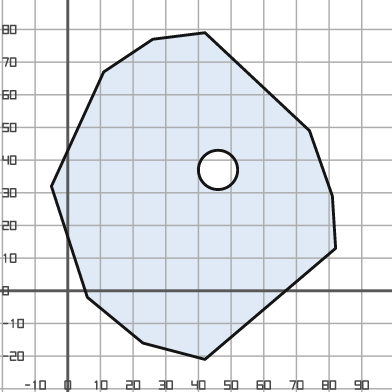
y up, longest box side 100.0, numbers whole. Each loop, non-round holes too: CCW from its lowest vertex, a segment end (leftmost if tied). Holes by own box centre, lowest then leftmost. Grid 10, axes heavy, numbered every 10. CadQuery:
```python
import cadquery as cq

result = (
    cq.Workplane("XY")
    .moveTo(42.0, -21.0)
    .lineTo(82.0, 13.0)
    .lineTo(81.0, 29.0)
    .lineTo(74.0, 49.0)
    .lineTo(42.0, 79.0)
    .lineTo(26.0, 77.0)
    .lineTo(11.0, 67.0)
    .lineTo(-5.0, 32.0)
    .lineTo(6.0, -2.0)
    .lineTo(23.0, -16.0)
    .close()
    .moveTo(46.0, 37.0)
    .circle(6.0)
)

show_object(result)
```